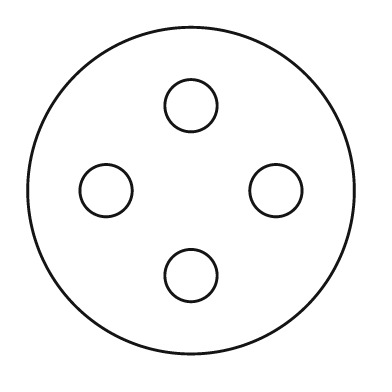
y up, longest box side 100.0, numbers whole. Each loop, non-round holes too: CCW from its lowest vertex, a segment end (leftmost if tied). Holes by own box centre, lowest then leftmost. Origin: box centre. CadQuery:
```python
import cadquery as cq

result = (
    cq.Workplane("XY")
    .moveTo(0.0, 0.0)
    .circle(50.0)
    .moveTo(0.0, -26.0)
    .circle(8.0)
    .moveTo(-26.0, 0.0)
    .circle(8.0)
    .moveTo(26.0, 0.0)
    .circle(8.0)
    .moveTo(0.0, 26.0)
    .circle(8.0)
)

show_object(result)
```